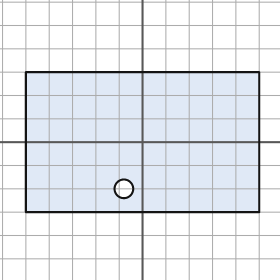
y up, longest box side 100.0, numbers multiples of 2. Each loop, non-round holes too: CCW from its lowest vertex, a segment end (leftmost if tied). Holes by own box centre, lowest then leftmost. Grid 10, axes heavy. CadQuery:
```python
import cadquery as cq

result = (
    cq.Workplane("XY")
    .moveTo(-50.0, -30.0)
    .lineTo(50.0, -30.0)
    .lineTo(50.0, 30.0)
    .lineTo(-50.0, 30.0)
    .close()
    .moveTo(-8.0, -20.0)
    .circle(4.0)
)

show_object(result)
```